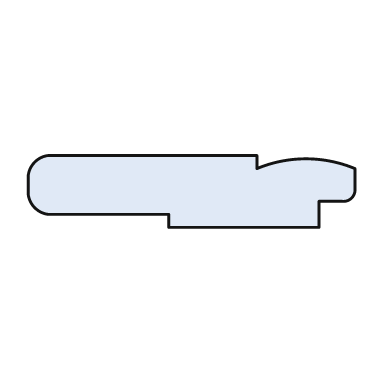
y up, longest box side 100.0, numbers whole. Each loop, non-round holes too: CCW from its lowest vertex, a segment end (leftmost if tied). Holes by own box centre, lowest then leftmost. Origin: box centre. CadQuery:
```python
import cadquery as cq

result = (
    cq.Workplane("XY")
    .moveTo(-7.0, -11.0)
    .lineTo(39.0, -11.0)
    .lineTo(39.0, -3.0)
    .lineTo(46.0, -3.0)
    .threePointArc((49.0, -2.0), (50.0, 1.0))
    .lineTo(50.0, 7.0)
    .threePointArc((35.0, 10.0), (20.0, 7.0))
    .lineTo(20.0, 11.0)
    .lineTo(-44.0, 11.0)
    .threePointArc((-48.0, 9.0), (-50.0, 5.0))
    .lineTo(-50.0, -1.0)
    .threePointArc((-48.0, -5.0), (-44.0, -7.0))
    .lineTo(-7.0, -7.0)
    .close()
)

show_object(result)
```